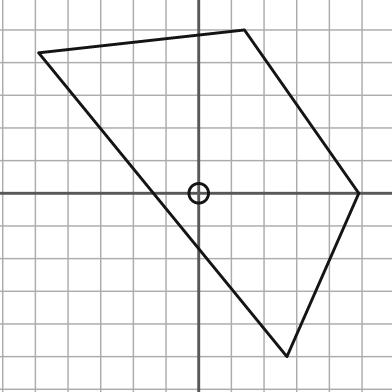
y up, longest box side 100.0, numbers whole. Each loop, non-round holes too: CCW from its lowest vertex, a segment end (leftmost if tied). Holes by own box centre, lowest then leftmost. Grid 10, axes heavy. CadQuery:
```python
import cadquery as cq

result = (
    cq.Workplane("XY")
    .moveTo(27.0, -50.0)
    .lineTo(49.0, 0.0)
    .lineTo(14.0, 50.0)
    .lineTo(-49.0, 43.0)
    .close()
    .moveTo(0.0, 0.0)
    .circle(3.0)
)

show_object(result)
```